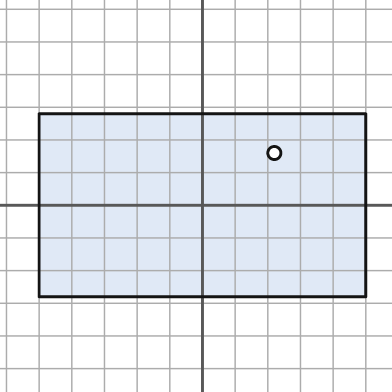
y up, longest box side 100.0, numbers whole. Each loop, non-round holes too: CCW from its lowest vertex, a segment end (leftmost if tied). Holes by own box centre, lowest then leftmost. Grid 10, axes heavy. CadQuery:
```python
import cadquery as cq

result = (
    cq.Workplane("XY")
    .moveTo(-50.0, -28.0)
    .lineTo(50.0, -28.0)
    .lineTo(50.0, 28.0)
    .lineTo(-50.0, 28.0)
    .close()
    .moveTo(22.0, 16.0)
    .circle(2.0)
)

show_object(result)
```